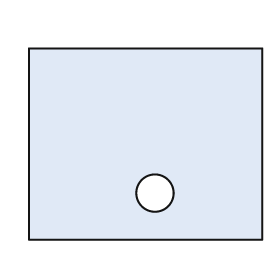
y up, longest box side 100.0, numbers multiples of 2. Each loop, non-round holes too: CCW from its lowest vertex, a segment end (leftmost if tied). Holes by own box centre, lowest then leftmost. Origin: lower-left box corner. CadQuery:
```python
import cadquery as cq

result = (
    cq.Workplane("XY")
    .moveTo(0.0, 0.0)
    .lineTo(100.0, 0.0)
    .lineTo(100.0, 82.0)
    .lineTo(0.0, 82.0)
    .close()
    .moveTo(54.0, 20.0)
    .circle(8.0)
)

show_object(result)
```